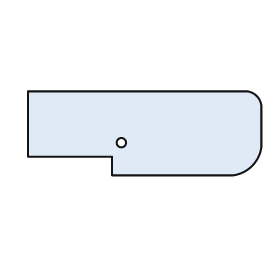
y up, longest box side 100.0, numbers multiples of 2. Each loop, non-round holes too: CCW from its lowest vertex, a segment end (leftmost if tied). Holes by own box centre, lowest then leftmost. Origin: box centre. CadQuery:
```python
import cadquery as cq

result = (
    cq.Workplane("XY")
    .moveTo(-14.0, -18.0)
    .lineTo(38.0, -18.0)
    .threePointArc((46.0, -14.0), (50.0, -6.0))
    .lineTo(50.0, 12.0)
    .threePointArc((48.0, 16.0), (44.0, 18.0))
    .lineTo(-50.0, 18.0)
    .lineTo(-50.0, -10.0)
    .lineTo(-14.0, -10.0)
    .close()
    .moveTo(-10.0, -4.0)
    .circle(2.0)
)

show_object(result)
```